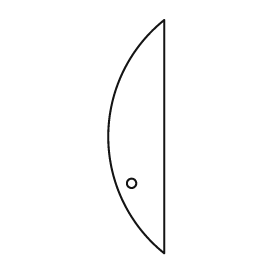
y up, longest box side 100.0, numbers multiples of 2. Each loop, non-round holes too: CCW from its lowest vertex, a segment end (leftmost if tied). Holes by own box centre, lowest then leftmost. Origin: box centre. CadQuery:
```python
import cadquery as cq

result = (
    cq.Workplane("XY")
    .moveTo(12.0, -50.0)
    .lineTo(12.0, 50.0)
    .threePointArc((-12.0, 0.0), (12.0, -50.0))
    .close()
    .moveTo(-2.0, -20.0)
    .circle(2.0)
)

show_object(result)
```